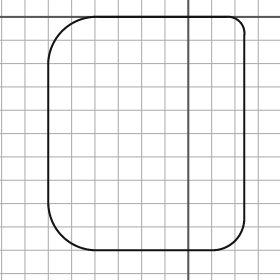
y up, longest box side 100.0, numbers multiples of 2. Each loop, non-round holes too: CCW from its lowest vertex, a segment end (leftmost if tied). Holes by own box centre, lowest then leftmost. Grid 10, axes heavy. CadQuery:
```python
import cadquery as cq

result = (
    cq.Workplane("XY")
    .moveTo(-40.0, -100.0)
    .lineTo(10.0, -100.0)
    .threePointArc((20.0, -96.0), (24.0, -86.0))
    .lineTo(24.0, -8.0)
    .threePointArc((22.0, -2.0), (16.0, 0.0))
    .lineTo(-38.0, 0.0)
    .threePointArc((-54.0, -6.0), (-60.0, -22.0))
    .lineTo(-60.0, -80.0)
    .threePointArc((-54.0, -94.0), (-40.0, -100.0))
    .close()
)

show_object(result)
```